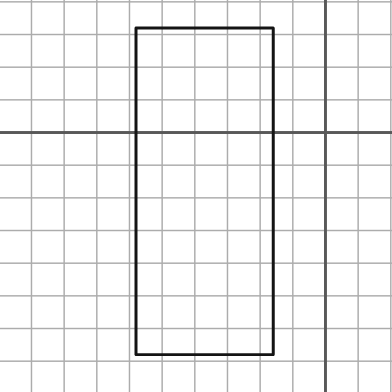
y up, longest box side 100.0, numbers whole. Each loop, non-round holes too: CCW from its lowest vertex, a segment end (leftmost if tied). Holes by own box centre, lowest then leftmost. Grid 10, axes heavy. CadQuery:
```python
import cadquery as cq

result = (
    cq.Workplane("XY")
    .moveTo(-58.0, -68.0)
    .lineTo(-16.0, -68.0)
    .lineTo(-16.0, 32.0)
    .lineTo(-58.0, 32.0)
    .close()
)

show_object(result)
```